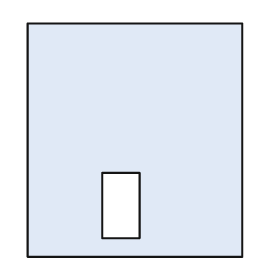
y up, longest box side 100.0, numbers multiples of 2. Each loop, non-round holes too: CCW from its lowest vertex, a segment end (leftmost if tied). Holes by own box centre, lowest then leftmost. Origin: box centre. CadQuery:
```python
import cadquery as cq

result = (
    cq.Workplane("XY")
    .moveTo(-46.0, -50.0)
    .lineTo(46.0, -50.0)
    .lineTo(46.0, 50.0)
    .lineTo(-46.0, 50.0)
    .close()
    .moveTo(-14.0, -42.0)
    .lineTo(2.0, -42.0)
    .lineTo(2.0, -14.0)
    .lineTo(-14.0, -14.0)
    .close()
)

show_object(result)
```